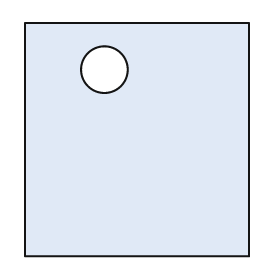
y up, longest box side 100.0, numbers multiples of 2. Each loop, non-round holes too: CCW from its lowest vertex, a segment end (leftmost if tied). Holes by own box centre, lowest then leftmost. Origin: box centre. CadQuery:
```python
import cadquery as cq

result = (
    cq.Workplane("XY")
    .moveTo(-48.0, -50.0)
    .lineTo(48.0, -50.0)
    .lineTo(48.0, 50.0)
    .lineTo(-48.0, 50.0)
    .close()
    .moveTo(-14.0, 30.0)
    .circle(10.0)
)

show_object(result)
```